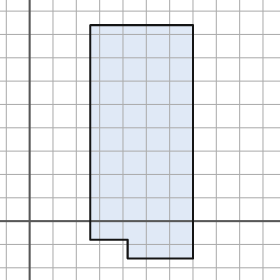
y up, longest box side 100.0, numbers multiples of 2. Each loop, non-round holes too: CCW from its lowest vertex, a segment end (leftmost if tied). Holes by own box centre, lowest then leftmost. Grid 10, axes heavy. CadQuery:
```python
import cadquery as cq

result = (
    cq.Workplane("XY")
    .moveTo(42.0, -16.0)
    .lineTo(70.0, -16.0)
    .lineTo(70.0, 84.0)
    .lineTo(26.0, 84.0)
    .lineTo(26.0, -8.0)
    .lineTo(42.0, -8.0)
    .close()
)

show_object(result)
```